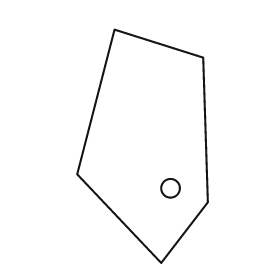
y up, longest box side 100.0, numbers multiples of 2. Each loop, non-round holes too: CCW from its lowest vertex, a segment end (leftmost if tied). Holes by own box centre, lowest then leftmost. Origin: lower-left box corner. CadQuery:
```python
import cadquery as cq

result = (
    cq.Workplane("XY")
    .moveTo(36.0, 0.0)
    .lineTo(56.0, 26.0)
    .lineTo(54.0, 88.0)
    .lineTo(16.0, 100.0)
    .lineTo(0.0, 38.0)
    .close()
    .moveTo(40.0, 32.0)
    .circle(4.0)
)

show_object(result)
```